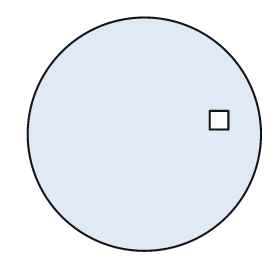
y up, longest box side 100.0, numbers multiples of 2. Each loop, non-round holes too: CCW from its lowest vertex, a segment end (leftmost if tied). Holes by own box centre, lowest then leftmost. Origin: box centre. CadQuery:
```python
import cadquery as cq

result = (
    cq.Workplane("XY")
    .moveTo(0.0, 0.0)
    .circle(50.0)
    .moveTo(28.0, 2.0)
    .lineTo(36.0, 2.0)
    .lineTo(36.0, 10.0)
    .lineTo(28.0, 10.0)
    .close()
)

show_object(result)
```